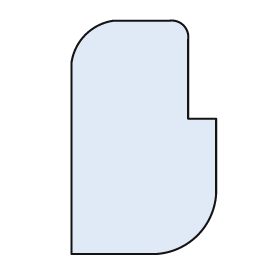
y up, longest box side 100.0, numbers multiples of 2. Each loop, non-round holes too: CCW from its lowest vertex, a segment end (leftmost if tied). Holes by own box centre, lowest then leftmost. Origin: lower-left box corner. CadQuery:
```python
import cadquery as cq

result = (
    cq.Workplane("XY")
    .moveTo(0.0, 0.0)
    .lineTo(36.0, 0.0)
    .threePointArc((54.0, 8.0), (62.0, 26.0))
    .lineTo(62.0, 58.0)
    .lineTo(50.0, 58.0)
    .lineTo(50.0, 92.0)
    .threePointArc((48.0, 98.0), (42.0, 100.0))
    .lineTo(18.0, 100.0)
    .threePointArc((6.0, 94.0), (0.0, 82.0))
    .close()
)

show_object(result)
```